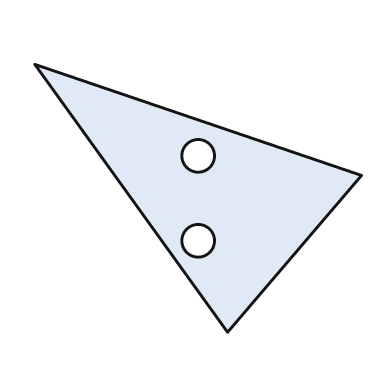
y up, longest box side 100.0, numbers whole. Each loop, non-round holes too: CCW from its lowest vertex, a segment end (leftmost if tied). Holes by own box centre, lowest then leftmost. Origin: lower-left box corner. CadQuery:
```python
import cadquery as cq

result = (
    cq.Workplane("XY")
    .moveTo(59.0, 0.0)
    .lineTo(100.0, 48.0)
    .lineTo(0.0, 82.0)
    .close()
    .moveTo(50.0, 28.0)
    .circle(5.0)
    .moveTo(50.0, 54.0)
    .circle(5.0)
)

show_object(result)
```